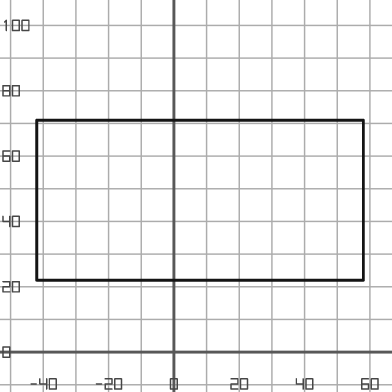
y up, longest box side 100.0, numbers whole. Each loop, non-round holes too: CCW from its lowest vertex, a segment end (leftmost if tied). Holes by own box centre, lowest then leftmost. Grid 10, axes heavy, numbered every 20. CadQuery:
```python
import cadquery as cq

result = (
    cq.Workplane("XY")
    .moveTo(-42.0, 22.0)
    .lineTo(58.0, 22.0)
    .lineTo(58.0, 71.0)
    .lineTo(-42.0, 71.0)
    .close()
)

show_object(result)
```